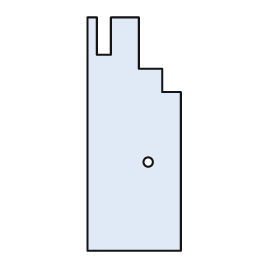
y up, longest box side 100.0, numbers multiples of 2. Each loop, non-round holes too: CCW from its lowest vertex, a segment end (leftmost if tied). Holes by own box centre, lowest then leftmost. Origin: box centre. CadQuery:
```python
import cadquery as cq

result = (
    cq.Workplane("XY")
    .moveTo(-20.0, -50.0)
    .lineTo(20.0, -50.0)
    .lineTo(20.0, 18.0)
    .lineTo(12.0, 18.0)
    .lineTo(12.0, 28.0)
    .lineTo(2.0, 28.0)
    .lineTo(2.0, 50.0)
    .lineTo(-10.0, 50.0)
    .lineTo(-10.0, 34.0)
    .lineTo(-16.0, 34.0)
    .lineTo(-16.0, 50.0)
    .lineTo(-20.0, 50.0)
    .close()
    .moveTo(6.0, -12.0)
    .circle(2.0)
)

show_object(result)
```